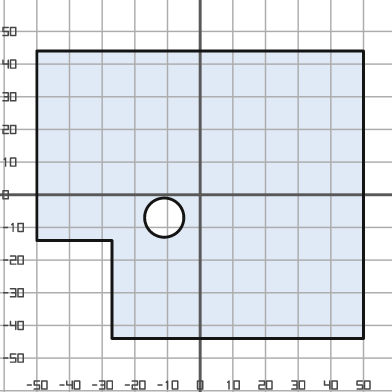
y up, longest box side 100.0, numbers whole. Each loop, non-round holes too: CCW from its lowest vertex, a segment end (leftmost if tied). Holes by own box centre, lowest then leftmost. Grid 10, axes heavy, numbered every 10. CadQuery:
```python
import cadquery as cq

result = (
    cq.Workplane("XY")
    .moveTo(-27.0, -44.0)
    .lineTo(50.0, -44.0)
    .lineTo(50.0, 44.0)
    .lineTo(-50.0, 44.0)
    .lineTo(-50.0, -14.0)
    .lineTo(-27.0, -14.0)
    .close()
    .moveTo(-11.0, -7.0)
    .circle(6.0)
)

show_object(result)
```